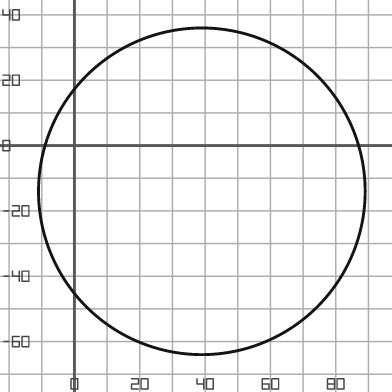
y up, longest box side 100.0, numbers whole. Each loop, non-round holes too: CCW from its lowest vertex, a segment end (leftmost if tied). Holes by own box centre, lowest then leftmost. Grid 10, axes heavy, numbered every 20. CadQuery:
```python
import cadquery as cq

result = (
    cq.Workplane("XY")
    .moveTo(39.0, -14.0)
    .circle(50.0)
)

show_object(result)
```